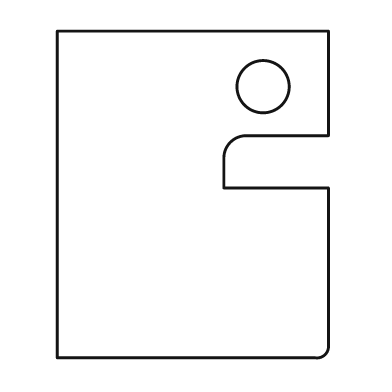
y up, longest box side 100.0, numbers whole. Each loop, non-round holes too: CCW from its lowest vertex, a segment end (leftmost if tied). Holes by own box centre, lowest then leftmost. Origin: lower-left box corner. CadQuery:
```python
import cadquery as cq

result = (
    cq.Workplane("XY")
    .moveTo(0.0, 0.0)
    .lineTo(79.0, 0.0)
    .threePointArc((82.0, 1.0), (83.0, 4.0))
    .lineTo(83.0, 52.0)
    .lineTo(51.0, 52.0)
    .lineTo(51.0, 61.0)
    .threePointArc((53.0, 66.0), (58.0, 68.0))
    .lineTo(83.0, 68.0)
    .lineTo(83.0, 100.0)
    .lineTo(0.0, 100.0)
    .close()
    .moveTo(63.0, 83.0)
    .circle(8.0)
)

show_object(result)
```